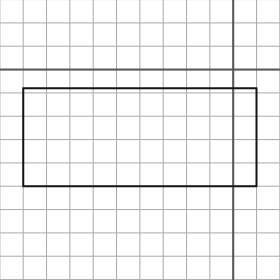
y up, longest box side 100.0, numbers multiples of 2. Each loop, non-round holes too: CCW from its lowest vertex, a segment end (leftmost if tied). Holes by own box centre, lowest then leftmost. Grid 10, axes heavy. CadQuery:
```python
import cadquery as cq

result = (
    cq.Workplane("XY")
    .moveTo(-90.0, -50.0)
    .lineTo(10.0, -50.0)
    .lineTo(10.0, -8.0)
    .lineTo(-90.0, -8.0)
    .close()
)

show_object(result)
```